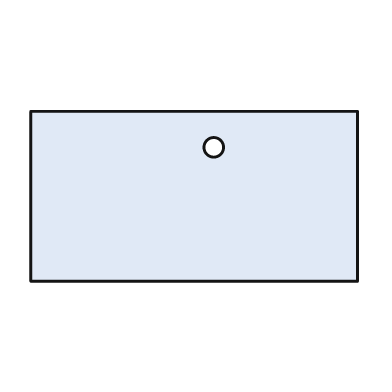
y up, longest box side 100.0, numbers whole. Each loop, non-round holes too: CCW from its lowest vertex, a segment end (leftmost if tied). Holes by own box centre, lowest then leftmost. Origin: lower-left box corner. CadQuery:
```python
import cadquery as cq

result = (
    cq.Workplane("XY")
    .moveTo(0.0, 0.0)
    .lineTo(100.0, 0.0)
    .lineTo(100.0, 52.0)
    .lineTo(0.0, 52.0)
    .close()
    .moveTo(56.0, 41.0)
    .circle(3.0)
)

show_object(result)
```